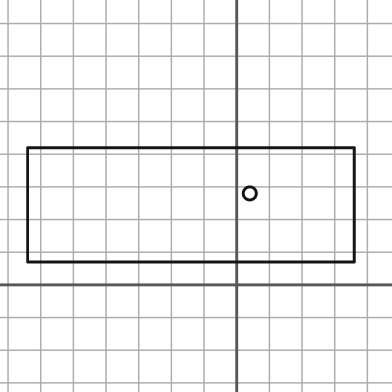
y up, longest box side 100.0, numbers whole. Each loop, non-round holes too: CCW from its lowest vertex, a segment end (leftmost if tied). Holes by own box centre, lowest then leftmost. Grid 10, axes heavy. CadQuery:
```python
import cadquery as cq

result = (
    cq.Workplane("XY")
    .moveTo(-64.0, 7.0)
    .lineTo(36.0, 7.0)
    .lineTo(36.0, 42.0)
    .lineTo(-64.0, 42.0)
    .close()
    .moveTo(4.0, 28.0)
    .circle(2.0)
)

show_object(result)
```